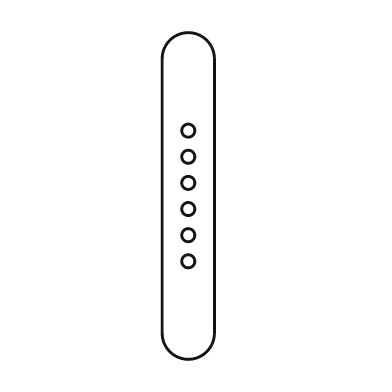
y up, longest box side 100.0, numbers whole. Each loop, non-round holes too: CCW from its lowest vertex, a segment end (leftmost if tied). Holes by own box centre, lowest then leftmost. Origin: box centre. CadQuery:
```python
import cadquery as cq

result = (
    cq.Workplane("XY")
    .moveTo(-8.0, -42.0)
    .threePointArc((0.0, -50.0), (8.0, -42.0))
    .lineTo(8.0, 42.0)
    .threePointArc((0.0, 50.0), (-8.0, 42.0))
    .close()
    .moveTo(0.0, -20.0)
    .circle(2.0)
    .moveTo(0.0, -12.0)
    .circle(2.0)
    .moveTo(0.0, -4.0)
    .circle(2.0)
    .moveTo(0.0, 4.0)
    .circle(2.0)
    .moveTo(0.0, 12.0)
    .circle(2.0)
    .moveTo(0.0, 20.0)
    .circle(2.0)
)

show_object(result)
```